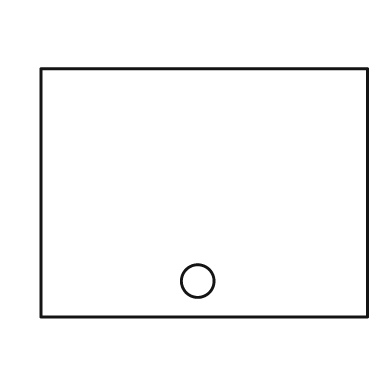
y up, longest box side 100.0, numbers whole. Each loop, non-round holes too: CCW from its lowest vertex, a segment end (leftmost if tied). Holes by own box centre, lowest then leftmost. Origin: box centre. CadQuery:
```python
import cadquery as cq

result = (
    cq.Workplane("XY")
    .moveTo(-50.0, -38.0)
    .lineTo(50.0, -38.0)
    .lineTo(50.0, 38.0)
    .lineTo(-50.0, 38.0)
    .close()
    .moveTo(-2.0, -27.0)
    .circle(5.0)
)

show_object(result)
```